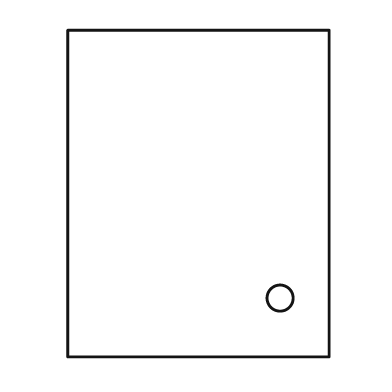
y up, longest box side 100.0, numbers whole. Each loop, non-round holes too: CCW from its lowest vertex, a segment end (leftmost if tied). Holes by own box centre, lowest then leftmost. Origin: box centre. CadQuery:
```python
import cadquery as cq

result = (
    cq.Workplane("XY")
    .moveTo(-40.0, -50.0)
    .lineTo(40.0, -50.0)
    .lineTo(40.0, 50.0)
    .lineTo(-40.0, 50.0)
    .close()
    .moveTo(25.0, -32.0)
    .circle(4.0)
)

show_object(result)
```